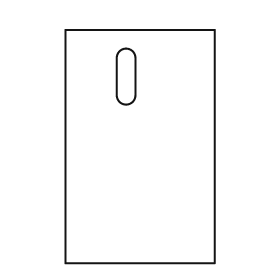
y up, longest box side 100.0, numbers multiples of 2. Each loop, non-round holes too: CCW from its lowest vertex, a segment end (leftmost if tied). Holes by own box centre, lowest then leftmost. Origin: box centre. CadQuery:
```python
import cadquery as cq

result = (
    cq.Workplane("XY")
    .moveTo(-32.0, -50.0)
    .lineTo(32.0, -50.0)
    .lineTo(32.0, 50.0)
    .lineTo(-32.0, 50.0)
    .close()
    .moveTo(-10.0, 22.0)
    .threePointArc((-6.0, 18.0), (-2.0, 22.0))
    .lineTo(-2.0, 38.0)
    .threePointArc((-6.0, 42.0), (-10.0, 38.0))
    .close()
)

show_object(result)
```